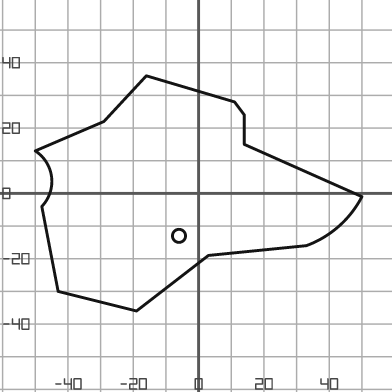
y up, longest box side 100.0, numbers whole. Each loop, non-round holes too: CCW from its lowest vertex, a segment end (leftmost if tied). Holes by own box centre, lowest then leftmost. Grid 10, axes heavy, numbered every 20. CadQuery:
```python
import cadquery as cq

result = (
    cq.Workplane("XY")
    .moveTo(-19.0, -36.0)
    .lineTo(3.0, -19.0)
    .lineTo(33.0, -16.0)
    .threePointArc((43.0, -10.0), (50.0, -1.0))
    .lineTo(14.0, 15.0)
    .lineTo(14.0, 24.0)
    .lineTo(11.0, 28.0)
    .lineTo(-16.0, 36.0)
    .lineTo(-29.0, 22.0)
    .lineTo(-50.0, 13.0)
    .threePointArc((-45.0, 5.0), (-48.0, -4.0))
    .lineTo(-43.0, -30.0)
    .close()
    .moveTo(-6.0, -13.0)
    .circle(2.0)
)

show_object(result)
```